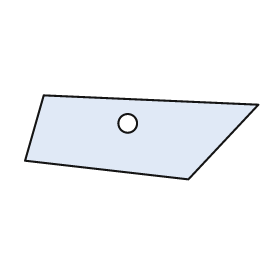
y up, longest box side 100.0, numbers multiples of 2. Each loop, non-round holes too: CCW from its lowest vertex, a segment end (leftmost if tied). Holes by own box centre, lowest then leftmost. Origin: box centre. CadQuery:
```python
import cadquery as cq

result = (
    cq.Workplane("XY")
    .moveTo(20.0, -18.0)
    .lineTo(50.0, 14.0)
    .lineTo(-42.0, 18.0)
    .lineTo(-50.0, -10.0)
    .close()
    .moveTo(-6.0, 6.0)
    .circle(4.0)
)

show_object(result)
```